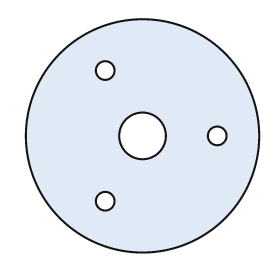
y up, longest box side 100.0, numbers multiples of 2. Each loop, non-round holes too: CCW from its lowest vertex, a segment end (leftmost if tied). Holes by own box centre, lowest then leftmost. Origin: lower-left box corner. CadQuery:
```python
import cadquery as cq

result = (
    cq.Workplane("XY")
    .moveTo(50.0, 50.0)
    .circle(50.0)
    .moveTo(34.0, 22.0)
    .circle(4.0)
    .moveTo(50.0, 50.0)
    .circle(10.0)
    .moveTo(82.0, 50.0)
    .circle(4.0)
    .moveTo(34.0, 78.0)
    .circle(4.0)
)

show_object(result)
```